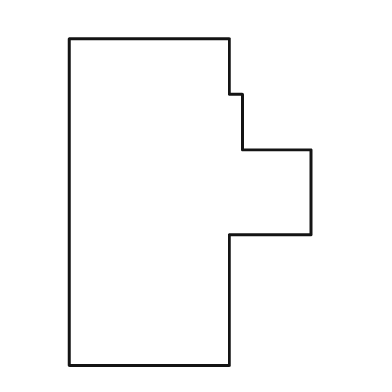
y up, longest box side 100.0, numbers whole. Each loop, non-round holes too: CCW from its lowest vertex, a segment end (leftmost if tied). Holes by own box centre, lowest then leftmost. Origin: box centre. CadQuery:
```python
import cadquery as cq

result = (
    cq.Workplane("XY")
    .moveTo(-37.0, -50.0)
    .lineTo(12.0, -50.0)
    .lineTo(12.0, -10.0)
    .lineTo(37.0, -10.0)
    .lineTo(37.0, 16.0)
    .lineTo(16.0, 16.0)
    .lineTo(16.0, 33.0)
    .lineTo(12.0, 33.0)
    .lineTo(12.0, 50.0)
    .lineTo(-37.0, 50.0)
    .close()
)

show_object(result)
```